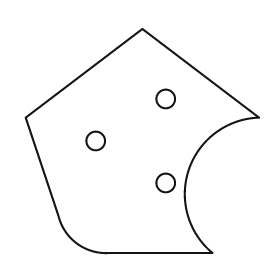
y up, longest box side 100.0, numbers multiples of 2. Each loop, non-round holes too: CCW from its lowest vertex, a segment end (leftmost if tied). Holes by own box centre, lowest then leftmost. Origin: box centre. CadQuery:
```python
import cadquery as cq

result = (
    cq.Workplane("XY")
    .moveTo(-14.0, -48.0)
    .lineTo(30.0, -48.0)
    .threePointArc((20.0, -12.0), (50.0, 10.0))
    .lineTo(0.0, 48.0)
    .lineTo(-50.0, 10.0)
    .lineTo(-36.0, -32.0)
    .threePointArc((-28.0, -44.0), (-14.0, -48.0))
    .close()
    .moveTo(10.0, -18.0)
    .circle(4.0)
    .moveTo(-20.0, 0.0)
    .circle(4.0)
    .moveTo(10.0, 18.0)
    .circle(4.0)
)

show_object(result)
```